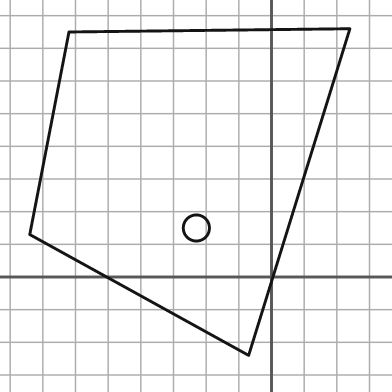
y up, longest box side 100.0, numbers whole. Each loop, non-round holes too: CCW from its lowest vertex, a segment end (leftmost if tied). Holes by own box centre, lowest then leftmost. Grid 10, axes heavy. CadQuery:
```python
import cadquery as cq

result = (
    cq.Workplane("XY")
    .moveTo(-7.0, -24.0)
    .lineTo(24.0, 76.0)
    .lineTo(-62.0, 75.0)
    .lineTo(-74.0, 13.0)
    .close()
    .moveTo(-23.0, 15.0)
    .circle(4.0)
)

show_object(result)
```